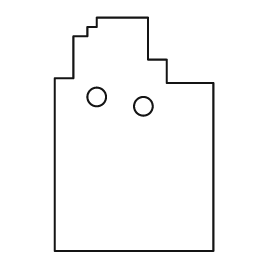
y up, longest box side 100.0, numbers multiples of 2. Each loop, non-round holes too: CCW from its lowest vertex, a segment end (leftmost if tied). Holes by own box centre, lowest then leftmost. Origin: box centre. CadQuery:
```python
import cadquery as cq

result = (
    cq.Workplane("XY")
    .moveTo(-34.0, -50.0)
    .lineTo(34.0, -50.0)
    .lineTo(34.0, 22.0)
    .lineTo(14.0, 22.0)
    .lineTo(14.0, 32.0)
    .lineTo(6.0, 32.0)
    .lineTo(6.0, 50.0)
    .lineTo(-16.0, 50.0)
    .lineTo(-16.0, 46.0)
    .lineTo(-20.0, 46.0)
    .lineTo(-20.0, 42.0)
    .lineTo(-26.0, 42.0)
    .lineTo(-26.0, 24.0)
    .lineTo(-34.0, 24.0)
    .close()
    .moveTo(4.0, 12.0)
    .circle(4.0)
    .moveTo(-16.0, 16.0)
    .circle(4.0)
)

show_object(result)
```